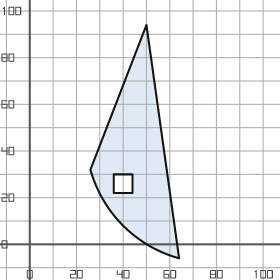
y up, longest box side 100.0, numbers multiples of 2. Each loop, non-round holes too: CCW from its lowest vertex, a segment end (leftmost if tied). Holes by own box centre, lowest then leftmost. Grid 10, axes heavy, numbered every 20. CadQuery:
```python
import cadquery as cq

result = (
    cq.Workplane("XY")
    .moveTo(64.0, -6.0)
    .lineTo(50.0, 94.0)
    .lineTo(26.0, 32.0)
    .threePointArc((40.0, 8.0), (64.0, -6.0))
    .close()
    .moveTo(36.0, 22.0)
    .lineTo(44.0, 22.0)
    .lineTo(44.0, 30.0)
    .lineTo(36.0, 30.0)
    .close()
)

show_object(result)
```